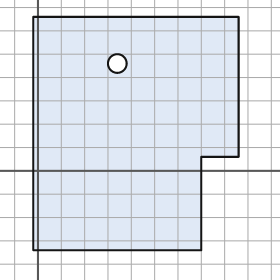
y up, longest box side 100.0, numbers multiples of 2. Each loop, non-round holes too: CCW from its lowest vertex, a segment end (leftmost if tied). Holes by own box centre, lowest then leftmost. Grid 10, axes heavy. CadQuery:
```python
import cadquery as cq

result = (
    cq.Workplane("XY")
    .moveTo(-2.0, -34.0)
    .lineTo(70.0, -34.0)
    .lineTo(70.0, 6.0)
    .lineTo(86.0, 6.0)
    .lineTo(86.0, 66.0)
    .lineTo(-2.0, 66.0)
    .close()
    .moveTo(34.0, 46.0)
    .circle(4.0)
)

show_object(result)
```